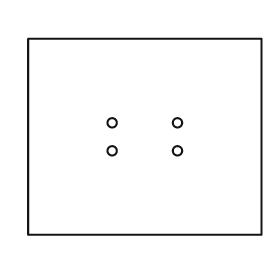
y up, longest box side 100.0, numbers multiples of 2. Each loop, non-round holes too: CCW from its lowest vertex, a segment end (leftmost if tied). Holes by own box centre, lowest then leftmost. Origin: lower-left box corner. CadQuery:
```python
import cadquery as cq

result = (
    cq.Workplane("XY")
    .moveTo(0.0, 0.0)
    .lineTo(100.0, 0.0)
    .lineTo(100.0, 84.0)
    .lineTo(0.0, 84.0)
    .close()
    .moveTo(36.0, 36.0)
    .circle(2.0)
    .moveTo(64.0, 36.0)
    .circle(2.0)
    .moveTo(36.0, 48.0)
    .circle(2.0)
    .moveTo(64.0, 48.0)
    .circle(2.0)
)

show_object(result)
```